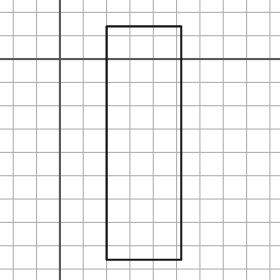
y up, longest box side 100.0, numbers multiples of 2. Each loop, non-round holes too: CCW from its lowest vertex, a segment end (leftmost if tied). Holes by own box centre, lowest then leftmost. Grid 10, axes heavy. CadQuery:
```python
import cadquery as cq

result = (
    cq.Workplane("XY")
    .moveTo(20.0, -86.0)
    .lineTo(52.0, -86.0)
    .lineTo(52.0, 14.0)
    .lineTo(20.0, 14.0)
    .close()
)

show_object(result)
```